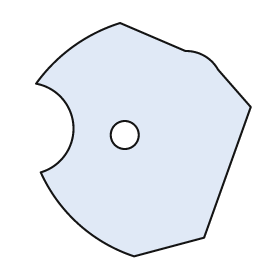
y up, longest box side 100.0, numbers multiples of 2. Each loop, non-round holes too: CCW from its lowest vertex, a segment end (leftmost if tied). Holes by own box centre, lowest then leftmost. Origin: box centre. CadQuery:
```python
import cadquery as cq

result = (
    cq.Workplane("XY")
    .moveTo(-4.0, -50.0)
    .lineTo(26.0, -42.0)
    .lineTo(46.0, 14.0)
    .lineTo(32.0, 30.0)
    .threePointArc((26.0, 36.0), (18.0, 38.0))
    .lineTo(-10.0, 50.0)
    .threePointArc((-30.0, 40.0), (-46.0, 24.0))
    .threePointArc((-30.0, 6.0), (-44.0, -14.0))
    .threePointArc((-28.0, -36.0), (-4.0, -50.0))
    .close()
    .moveTo(-8.0, 2.0)
    .circle(6.0)
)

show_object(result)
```